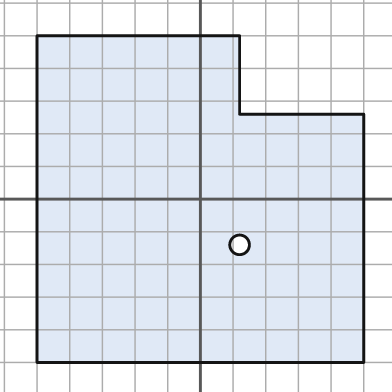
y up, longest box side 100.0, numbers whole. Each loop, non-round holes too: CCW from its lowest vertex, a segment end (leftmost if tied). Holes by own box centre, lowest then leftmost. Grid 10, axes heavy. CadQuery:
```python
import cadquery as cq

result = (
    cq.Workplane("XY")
    .moveTo(-50.0, -50.0)
    .lineTo(50.0, -50.0)
    .lineTo(50.0, 26.0)
    .lineTo(12.0, 26.0)
    .lineTo(12.0, 50.0)
    .lineTo(-50.0, 50.0)
    .close()
    .moveTo(12.0, -14.0)
    .circle(3.0)
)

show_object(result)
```